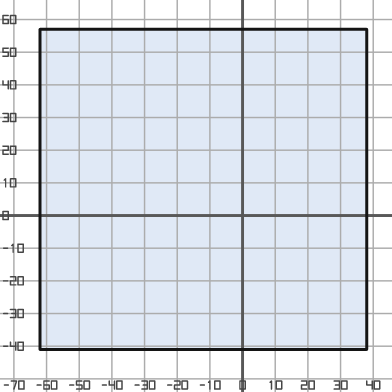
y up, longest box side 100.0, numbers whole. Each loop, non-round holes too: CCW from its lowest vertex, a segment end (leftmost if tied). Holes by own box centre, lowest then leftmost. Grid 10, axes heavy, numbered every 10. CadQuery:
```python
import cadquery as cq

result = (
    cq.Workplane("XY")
    .moveTo(-62.0, -41.0)
    .lineTo(38.0, -41.0)
    .lineTo(38.0, 57.0)
    .lineTo(-62.0, 57.0)
    .close()
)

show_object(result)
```